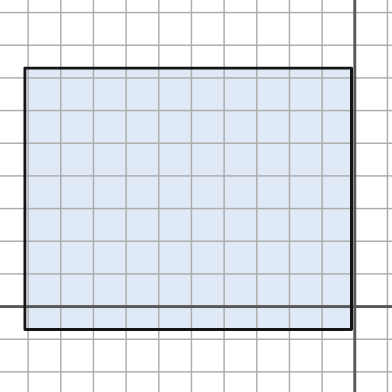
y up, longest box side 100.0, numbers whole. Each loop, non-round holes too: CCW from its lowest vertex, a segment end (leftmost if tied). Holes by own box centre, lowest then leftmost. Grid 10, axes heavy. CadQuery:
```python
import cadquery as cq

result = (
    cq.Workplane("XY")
    .moveTo(-101.0, -7.0)
    .lineTo(-1.0, -7.0)
    .lineTo(-1.0, 73.0)
    .lineTo(-101.0, 73.0)
    .close()
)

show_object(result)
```